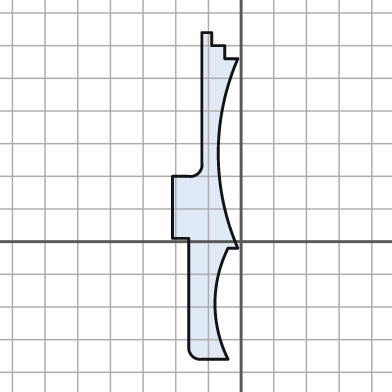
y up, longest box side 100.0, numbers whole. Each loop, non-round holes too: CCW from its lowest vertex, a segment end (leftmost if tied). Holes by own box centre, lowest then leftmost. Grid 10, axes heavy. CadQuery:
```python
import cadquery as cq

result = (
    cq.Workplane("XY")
    .moveTo(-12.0, -36.0)
    .lineTo(-4.0, -36.0)
    .threePointArc((-8.0, -19.0), (-4.0, -2.0))
    .lineTo(-1.0, -2.0)
    .threePointArc((-7.0, 27.0), (-1.0, 56.0))
    .lineTo(-5.0, 56.0)
    .lineTo(-5.0, 60.0)
    .lineTo(-9.0, 60.0)
    .lineTo(-9.0, 64.0)
    .lineTo(-12.0, 64.0)
    .lineTo(-12.0, 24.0)
    .threePointArc((-13.0, 21.0), (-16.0, 20.0))
    .lineTo(-21.0, 20.0)
    .lineTo(-21.0, 1.0)
    .lineTo(-16.0, 1.0)
    .lineTo(-16.0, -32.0)
    .threePointArc((-15.0, -35.0), (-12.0, -36.0))
    .close()
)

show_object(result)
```